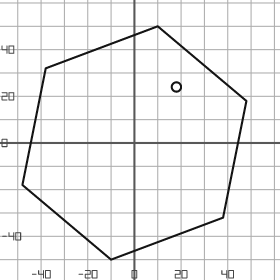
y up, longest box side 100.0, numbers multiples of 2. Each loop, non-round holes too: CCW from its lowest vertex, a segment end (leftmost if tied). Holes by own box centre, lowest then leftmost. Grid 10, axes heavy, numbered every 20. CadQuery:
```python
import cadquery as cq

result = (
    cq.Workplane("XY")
    .moveTo(-10.0, -50.0)
    .lineTo(38.0, -32.0)
    .lineTo(48.0, 18.0)
    .lineTo(10.0, 50.0)
    .lineTo(-38.0, 32.0)
    .lineTo(-48.0, -18.0)
    .close()
    .moveTo(18.0, 24.0)
    .circle(2.0)
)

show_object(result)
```